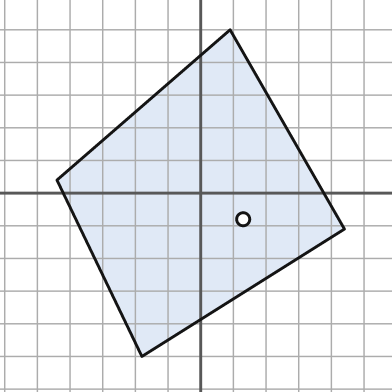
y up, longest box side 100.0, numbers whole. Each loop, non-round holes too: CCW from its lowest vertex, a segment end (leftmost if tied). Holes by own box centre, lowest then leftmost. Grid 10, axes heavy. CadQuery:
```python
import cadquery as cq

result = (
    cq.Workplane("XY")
    .moveTo(-18.0, -50.0)
    .lineTo(44.0, -11.0)
    .lineTo(9.0, 50.0)
    .lineTo(-44.0, 4.0)
    .close()
    .moveTo(13.0, -8.0)
    .circle(2.0)
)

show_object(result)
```